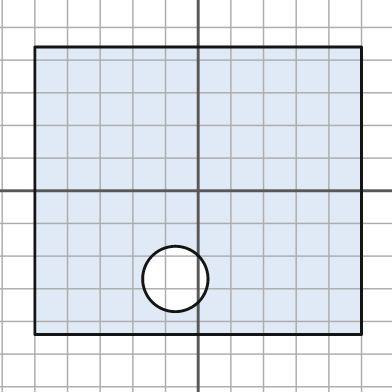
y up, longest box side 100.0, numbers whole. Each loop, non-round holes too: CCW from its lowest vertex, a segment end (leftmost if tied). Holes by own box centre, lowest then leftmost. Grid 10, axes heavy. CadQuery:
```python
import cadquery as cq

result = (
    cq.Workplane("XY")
    .moveTo(-50.0, -44.0)
    .lineTo(50.0, -44.0)
    .lineTo(50.0, 44.0)
    .lineTo(-50.0, 44.0)
    .close()
    .moveTo(-7.0, -27.0)
    .circle(10.0)
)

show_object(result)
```